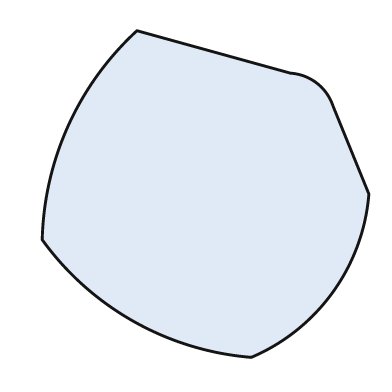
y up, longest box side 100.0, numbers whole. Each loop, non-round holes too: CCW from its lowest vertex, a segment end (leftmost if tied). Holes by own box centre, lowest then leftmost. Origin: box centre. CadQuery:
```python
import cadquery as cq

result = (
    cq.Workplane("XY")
    .moveTo(14.0, -50.0)
    .threePointArc((39.0, -30.0), (50.0, 0.0))
    .lineTo(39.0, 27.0)
    .threePointArc((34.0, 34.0), (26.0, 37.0))
    .lineTo(-21.0, 50.0)
    .threePointArc((-42.0, 21.0), (-50.0, -14.0))
    .threePointArc((-22.0, -39.0), (14.0, -50.0))
    .close()
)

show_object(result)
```